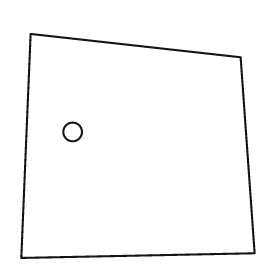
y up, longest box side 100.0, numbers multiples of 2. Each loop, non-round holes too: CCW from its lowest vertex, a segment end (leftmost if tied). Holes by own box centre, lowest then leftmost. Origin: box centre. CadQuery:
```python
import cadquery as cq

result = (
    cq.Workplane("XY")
    .moveTo(-50.0, -48.0)
    .lineTo(50.0, -46.0)
    .lineTo(44.0, 38.0)
    .lineTo(-46.0, 48.0)
    .close()
    .moveTo(-28.0, 6.0)
    .circle(4.0)
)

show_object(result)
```